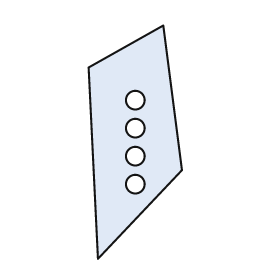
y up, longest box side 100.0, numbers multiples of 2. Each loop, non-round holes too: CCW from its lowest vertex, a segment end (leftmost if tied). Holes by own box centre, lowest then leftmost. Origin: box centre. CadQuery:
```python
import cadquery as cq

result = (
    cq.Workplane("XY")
    .moveTo(-16.0, -50.0)
    .lineTo(20.0, -12.0)
    .lineTo(12.0, 50.0)
    .lineTo(-20.0, 32.0)
    .close()
    .moveTo(0.0, -18.0)
    .circle(4.0)
    .moveTo(0.0, -6.0)
    .circle(4.0)
    .moveTo(0.0, 6.0)
    .circle(4.0)
    .moveTo(0.0, 18.0)
    .circle(4.0)
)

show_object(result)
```